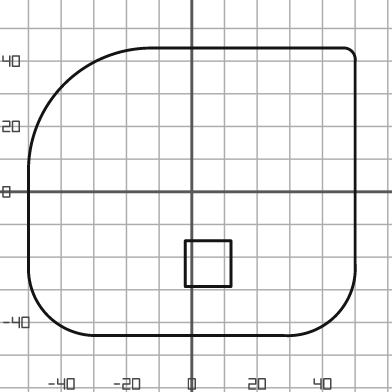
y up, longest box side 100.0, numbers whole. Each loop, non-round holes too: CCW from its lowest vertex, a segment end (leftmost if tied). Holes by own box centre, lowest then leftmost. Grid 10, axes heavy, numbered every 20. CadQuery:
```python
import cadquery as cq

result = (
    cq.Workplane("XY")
    .moveTo(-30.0, -44.0)
    .lineTo(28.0, -44.0)
    .threePointArc((44.0, -38.0), (50.0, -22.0))
    .lineTo(50.0, 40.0)
    .threePointArc((49.0, 43.0), (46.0, 44.0))
    .lineTo(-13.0, 44.0)
    .threePointArc((-39.0, 33.0), (-50.0, 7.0))
    .lineTo(-50.0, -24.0)
    .threePointArc((-44.0, -38.0), (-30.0, -44.0))
    .close()
    .moveTo(-2.0, -29.0)
    .lineTo(12.0, -29.0)
    .lineTo(12.0, -15.0)
    .lineTo(-2.0, -15.0)
    .close()
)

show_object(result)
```